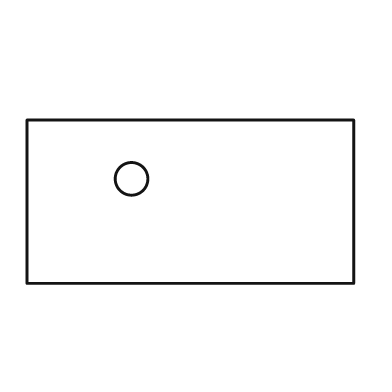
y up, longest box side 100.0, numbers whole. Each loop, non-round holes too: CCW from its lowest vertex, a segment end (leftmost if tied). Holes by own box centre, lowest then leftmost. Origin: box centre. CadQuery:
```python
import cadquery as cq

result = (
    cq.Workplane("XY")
    .moveTo(-50.0, -25.0)
    .lineTo(50.0, -25.0)
    .lineTo(50.0, 25.0)
    .lineTo(-50.0, 25.0)
    .close()
    .moveTo(-18.0, 7.0)
    .circle(5.0)
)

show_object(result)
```